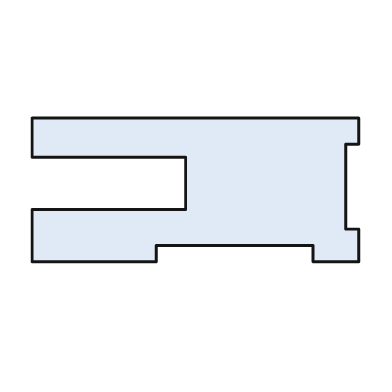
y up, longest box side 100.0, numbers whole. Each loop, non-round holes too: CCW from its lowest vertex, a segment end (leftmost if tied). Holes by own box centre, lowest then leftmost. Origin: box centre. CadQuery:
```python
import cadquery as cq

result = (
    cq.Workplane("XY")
    .moveTo(-50.0, -22.0)
    .lineTo(-12.0, -22.0)
    .lineTo(-12.0, -17.0)
    .lineTo(36.0, -17.0)
    .lineTo(36.0, -22.0)
    .lineTo(50.0, -22.0)
    .lineTo(50.0, -12.0)
    .lineTo(46.0, -12.0)
    .lineTo(46.0, 14.0)
    .lineTo(50.0, 14.0)
    .lineTo(50.0, 22.0)
    .lineTo(-50.0, 22.0)
    .lineTo(-50.0, 10.0)
    .lineTo(-3.0, 10.0)
    .lineTo(-3.0, -6.0)
    .lineTo(-50.0, -6.0)
    .close()
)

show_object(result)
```